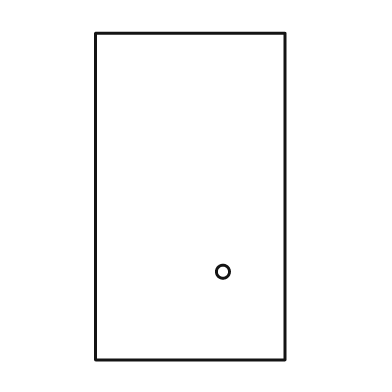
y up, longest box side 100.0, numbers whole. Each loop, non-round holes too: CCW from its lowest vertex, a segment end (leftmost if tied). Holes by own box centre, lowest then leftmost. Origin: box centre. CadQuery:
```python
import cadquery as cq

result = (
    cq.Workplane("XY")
    .moveTo(-29.0, -50.0)
    .lineTo(29.0, -50.0)
    .lineTo(29.0, 50.0)
    .lineTo(-29.0, 50.0)
    .close()
    .moveTo(10.0, -23.0)
    .circle(2.0)
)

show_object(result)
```